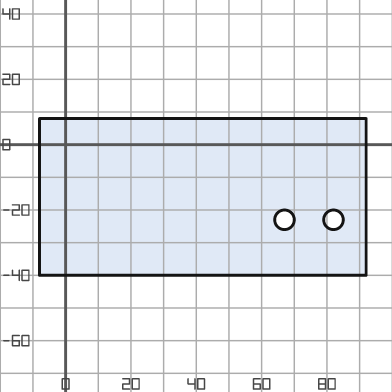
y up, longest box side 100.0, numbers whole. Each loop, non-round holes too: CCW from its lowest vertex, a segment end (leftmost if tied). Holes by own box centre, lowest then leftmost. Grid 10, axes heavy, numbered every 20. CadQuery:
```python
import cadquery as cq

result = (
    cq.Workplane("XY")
    .moveTo(-8.0, -40.0)
    .lineTo(92.0, -40.0)
    .lineTo(92.0, 8.0)
    .lineTo(-8.0, 8.0)
    .close()
    .moveTo(67.0, -23.0)
    .circle(3.0)
    .moveTo(82.0, -23.0)
    .circle(3.0)
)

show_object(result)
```